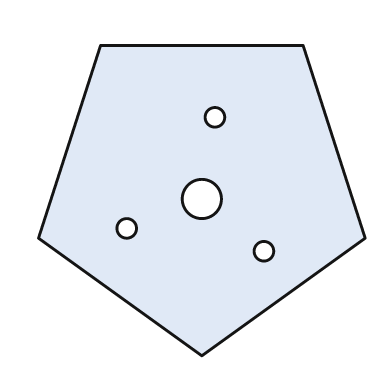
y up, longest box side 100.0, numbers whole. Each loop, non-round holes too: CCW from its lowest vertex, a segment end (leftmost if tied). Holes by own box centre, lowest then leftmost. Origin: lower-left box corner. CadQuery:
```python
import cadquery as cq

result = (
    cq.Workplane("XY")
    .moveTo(50.0, 0.0)
    .lineTo(100.0, 36.0)
    .lineTo(81.0, 95.0)
    .lineTo(19.0, 95.0)
    .lineTo(0.0, 36.0)
    .close()
    .moveTo(69.0, 32.0)
    .circle(3.0)
    .moveTo(27.0, 39.0)
    .circle(3.0)
    .moveTo(50.0, 48.0)
    .circle(6.0)
    .moveTo(54.0, 73.0)
    .circle(3.0)
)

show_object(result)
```